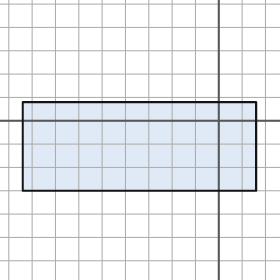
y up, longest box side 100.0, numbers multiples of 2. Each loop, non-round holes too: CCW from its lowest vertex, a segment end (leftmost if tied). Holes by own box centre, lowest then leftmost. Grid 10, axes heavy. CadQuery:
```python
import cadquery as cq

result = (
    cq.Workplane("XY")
    .moveTo(-84.0, -30.0)
    .lineTo(16.0, -30.0)
    .lineTo(16.0, 8.0)
    .lineTo(-84.0, 8.0)
    .close()
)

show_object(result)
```